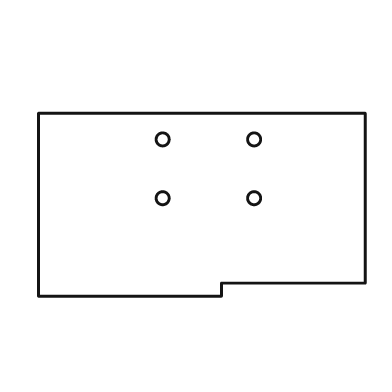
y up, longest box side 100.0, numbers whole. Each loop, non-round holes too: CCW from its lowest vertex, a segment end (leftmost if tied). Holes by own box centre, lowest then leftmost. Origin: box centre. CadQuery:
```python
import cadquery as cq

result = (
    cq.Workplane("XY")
    .moveTo(-50.0, -28.0)
    .lineTo(6.0, -28.0)
    .lineTo(6.0, -24.0)
    .lineTo(50.0, -24.0)
    .lineTo(50.0, 28.0)
    .lineTo(-50.0, 28.0)
    .close()
    .moveTo(-12.0, 2.0)
    .circle(2.0)
    .moveTo(16.0, 2.0)
    .circle(2.0)
    .moveTo(-12.0, 20.0)
    .circle(2.0)
    .moveTo(16.0, 20.0)
    .circle(2.0)
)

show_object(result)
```